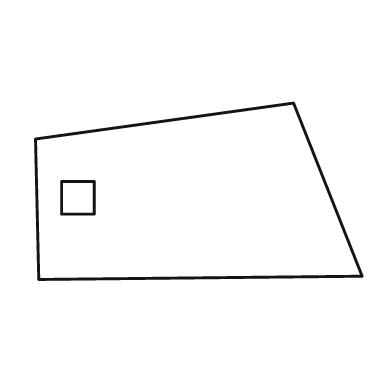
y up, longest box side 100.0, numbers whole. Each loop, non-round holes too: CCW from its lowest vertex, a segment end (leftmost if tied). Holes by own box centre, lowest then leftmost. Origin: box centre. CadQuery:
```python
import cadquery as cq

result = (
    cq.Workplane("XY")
    .moveTo(-49.0, -27.0)
    .lineTo(50.0, -26.0)
    .lineTo(29.0, 27.0)
    .lineTo(-50.0, 16.0)
    .close()
    .moveTo(-42.0, -7.0)
    .lineTo(-32.0, -7.0)
    .lineTo(-32.0, 3.0)
    .lineTo(-42.0, 3.0)
    .close()
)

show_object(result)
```